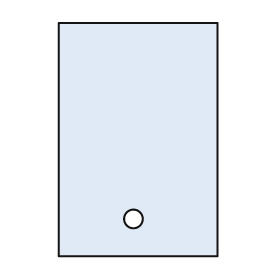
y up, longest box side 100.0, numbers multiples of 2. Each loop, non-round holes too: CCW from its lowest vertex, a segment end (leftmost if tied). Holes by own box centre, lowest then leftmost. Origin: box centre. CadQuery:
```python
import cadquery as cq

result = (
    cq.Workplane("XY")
    .moveTo(-34.0, -50.0)
    .lineTo(34.0, -50.0)
    .lineTo(34.0, 50.0)
    .lineTo(-34.0, 50.0)
    .close()
    .moveTo(-2.0, -34.0)
    .circle(4.0)
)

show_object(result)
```